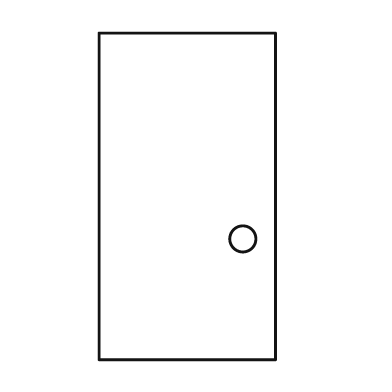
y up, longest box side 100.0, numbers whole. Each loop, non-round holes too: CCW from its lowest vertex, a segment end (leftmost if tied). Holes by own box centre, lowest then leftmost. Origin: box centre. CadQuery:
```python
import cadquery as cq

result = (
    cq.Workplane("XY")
    .moveTo(-27.0, -50.0)
    .lineTo(27.0, -50.0)
    .lineTo(27.0, 50.0)
    .lineTo(-27.0, 50.0)
    .close()
    .moveTo(17.0, -13.0)
    .circle(4.0)
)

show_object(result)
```